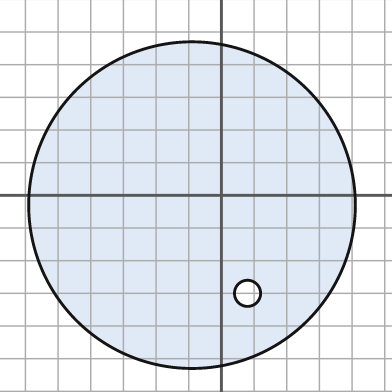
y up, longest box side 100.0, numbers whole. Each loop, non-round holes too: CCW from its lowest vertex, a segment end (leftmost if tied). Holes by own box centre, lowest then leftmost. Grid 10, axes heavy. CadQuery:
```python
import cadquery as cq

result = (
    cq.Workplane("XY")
    .moveTo(-9.0, -3.0)
    .circle(50.0)
    .moveTo(8.0, -30.0)
    .circle(4.0)
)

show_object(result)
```